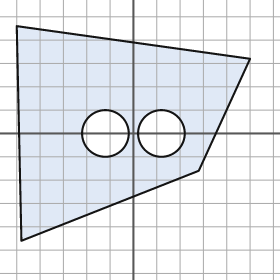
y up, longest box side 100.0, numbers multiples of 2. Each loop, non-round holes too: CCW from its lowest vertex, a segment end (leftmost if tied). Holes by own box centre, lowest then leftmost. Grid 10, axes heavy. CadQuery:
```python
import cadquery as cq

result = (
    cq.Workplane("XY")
    .moveTo(-48.0, -46.0)
    .lineTo(28.0, -16.0)
    .lineTo(50.0, 32.0)
    .lineTo(-50.0, 46.0)
    .close()
    .moveTo(-12.0, 0.0)
    .circle(10.0)
    .moveTo(12.0, 0.0)
    .circle(10.0)
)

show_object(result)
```